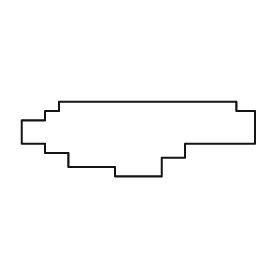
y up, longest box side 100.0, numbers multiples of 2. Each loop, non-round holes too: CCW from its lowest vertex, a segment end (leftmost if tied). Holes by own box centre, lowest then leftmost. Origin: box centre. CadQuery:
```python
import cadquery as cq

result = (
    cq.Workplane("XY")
    .moveTo(-10.0, -16.0)
    .lineTo(10.0, -16.0)
    .lineTo(10.0, -8.0)
    .lineTo(20.0, -8.0)
    .lineTo(20.0, -2.0)
    .lineTo(50.0, -2.0)
    .lineTo(50.0, 12.0)
    .lineTo(42.0, 12.0)
    .lineTo(42.0, 16.0)
    .lineTo(-34.0, 16.0)
    .lineTo(-34.0, 12.0)
    .lineTo(-40.0, 12.0)
    .lineTo(-40.0, 8.0)
    .lineTo(-50.0, 8.0)
    .lineTo(-50.0, -2.0)
    .lineTo(-40.0, -2.0)
    .lineTo(-40.0, -6.0)
    .lineTo(-30.0, -6.0)
    .lineTo(-30.0, -12.0)
    .lineTo(-10.0, -12.0)
    .close()
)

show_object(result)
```